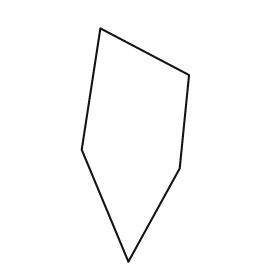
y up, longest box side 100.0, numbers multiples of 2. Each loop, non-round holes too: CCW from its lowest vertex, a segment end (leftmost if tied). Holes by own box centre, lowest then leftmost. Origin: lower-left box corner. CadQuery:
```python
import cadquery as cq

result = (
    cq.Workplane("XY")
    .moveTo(20.0, 0.0)
    .lineTo(42.0, 40.0)
    .lineTo(46.0, 80.0)
    .lineTo(8.0, 100.0)
    .lineTo(0.0, 48.0)
    .close()
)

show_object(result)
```